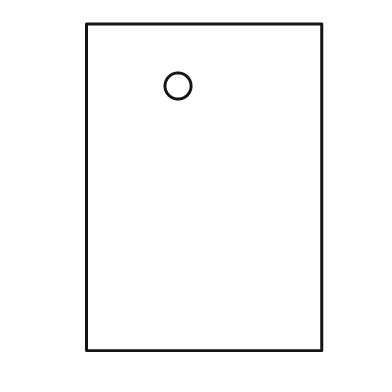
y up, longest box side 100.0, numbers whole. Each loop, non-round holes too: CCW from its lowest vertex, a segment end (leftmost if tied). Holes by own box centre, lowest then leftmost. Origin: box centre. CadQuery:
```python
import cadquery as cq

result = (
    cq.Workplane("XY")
    .moveTo(-36.0, -50.0)
    .lineTo(36.0, -50.0)
    .lineTo(36.0, 50.0)
    .lineTo(-36.0, 50.0)
    .close()
    .moveTo(-8.0, 31.0)
    .circle(4.0)
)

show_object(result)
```